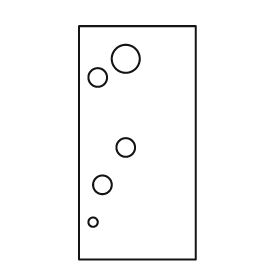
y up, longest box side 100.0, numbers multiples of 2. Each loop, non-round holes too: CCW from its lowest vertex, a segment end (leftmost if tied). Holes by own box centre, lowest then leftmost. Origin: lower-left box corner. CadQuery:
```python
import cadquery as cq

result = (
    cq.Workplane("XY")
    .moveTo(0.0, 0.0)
    .lineTo(50.0, 0.0)
    .lineTo(50.0, 100.0)
    .lineTo(0.0, 100.0)
    .close()
    .moveTo(6.0, 16.0)
    .circle(2.0)
    .moveTo(10.0, 32.0)
    .circle(4.0)
    .moveTo(20.0, 48.0)
    .circle(4.0)
    .moveTo(8.0, 78.0)
    .circle(4.0)
    .moveTo(20.0, 86.0)
    .circle(6.0)
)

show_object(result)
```